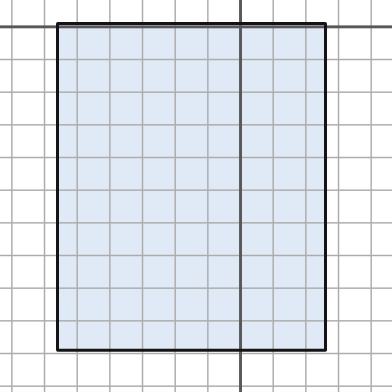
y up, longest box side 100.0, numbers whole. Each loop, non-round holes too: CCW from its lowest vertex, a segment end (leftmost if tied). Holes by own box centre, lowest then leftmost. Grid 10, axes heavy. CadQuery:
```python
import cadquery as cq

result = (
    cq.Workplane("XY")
    .moveTo(-56.0, -99.0)
    .lineTo(26.0, -99.0)
    .lineTo(26.0, 1.0)
    .lineTo(-56.0, 1.0)
    .close()
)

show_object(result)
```